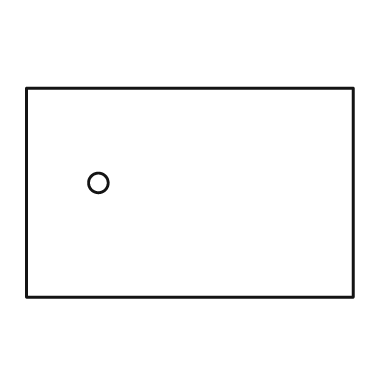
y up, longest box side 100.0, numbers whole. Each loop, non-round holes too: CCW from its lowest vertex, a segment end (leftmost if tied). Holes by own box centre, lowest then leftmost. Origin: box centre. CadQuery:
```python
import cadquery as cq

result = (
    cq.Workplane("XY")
    .moveTo(-50.0, -32.0)
    .lineTo(50.0, -32.0)
    .lineTo(50.0, 32.0)
    .lineTo(-50.0, 32.0)
    .close()
    .moveTo(-28.0, 3.0)
    .circle(3.0)
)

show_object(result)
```